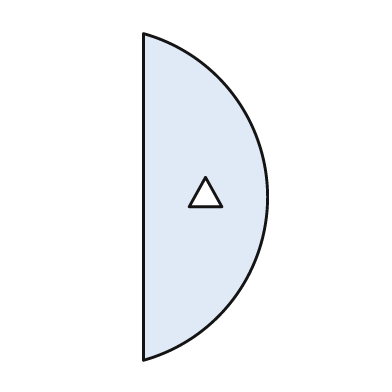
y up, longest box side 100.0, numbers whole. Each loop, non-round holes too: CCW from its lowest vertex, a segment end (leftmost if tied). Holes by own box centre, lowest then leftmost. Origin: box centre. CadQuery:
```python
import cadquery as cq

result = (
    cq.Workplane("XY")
    .moveTo(-19.0, -50.0)
    .threePointArc((19.0, 0.0), (-19.0, 50.0))
    .close()
    .moveTo(-5.0, -3.0)
    .lineTo(5.0, -3.0)
    .lineTo(0.0, 6.0)
    .close()
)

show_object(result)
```